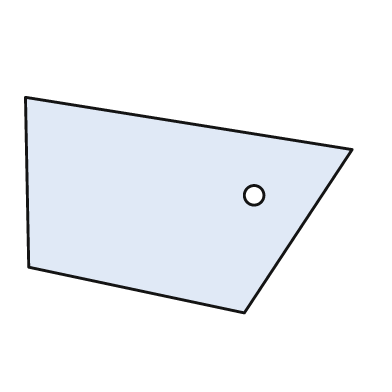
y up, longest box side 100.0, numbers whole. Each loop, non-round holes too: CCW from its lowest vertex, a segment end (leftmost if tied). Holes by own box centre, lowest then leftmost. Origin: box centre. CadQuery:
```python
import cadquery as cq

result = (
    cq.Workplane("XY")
    .moveTo(17.0, -33.0)
    .lineTo(50.0, 17.0)
    .lineTo(-50.0, 33.0)
    .lineTo(-49.0, -19.0)
    .close()
    .moveTo(20.0, 3.0)
    .circle(3.0)
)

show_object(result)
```